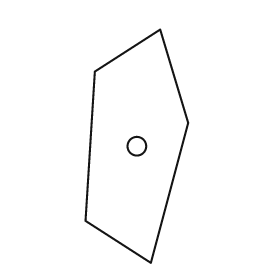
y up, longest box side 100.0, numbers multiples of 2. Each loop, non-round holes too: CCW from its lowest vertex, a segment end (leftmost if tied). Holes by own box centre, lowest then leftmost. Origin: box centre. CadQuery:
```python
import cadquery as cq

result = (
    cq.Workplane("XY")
    .moveTo(6.0, -50.0)
    .lineTo(22.0, 10.0)
    .lineTo(10.0, 50.0)
    .lineTo(-18.0, 32.0)
    .lineTo(-22.0, -32.0)
    .close()
    .moveTo(0.0, 0.0)
    .circle(4.0)
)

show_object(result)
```